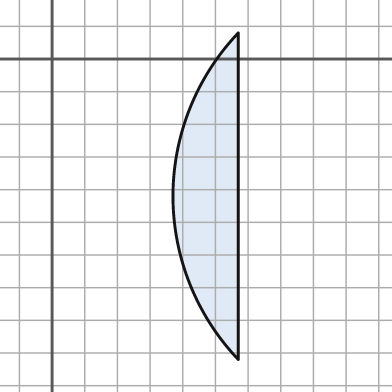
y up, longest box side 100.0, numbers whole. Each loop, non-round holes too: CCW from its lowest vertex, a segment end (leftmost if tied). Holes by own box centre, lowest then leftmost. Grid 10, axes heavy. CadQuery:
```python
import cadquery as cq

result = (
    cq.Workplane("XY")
    .moveTo(57.0, -92.0)
    .lineTo(57.0, 8.0)
    .threePointArc((37.0, -42.0), (57.0, -92.0))
    .close()
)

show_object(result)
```